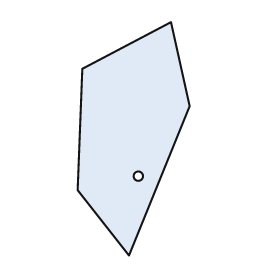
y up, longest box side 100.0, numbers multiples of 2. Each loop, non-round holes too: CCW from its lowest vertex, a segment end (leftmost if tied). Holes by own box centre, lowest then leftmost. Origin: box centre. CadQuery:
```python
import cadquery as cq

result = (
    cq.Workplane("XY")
    .moveTo(-2.0, -50.0)
    .lineTo(24.0, 14.0)
    .lineTo(16.0, 50.0)
    .lineTo(-22.0, 30.0)
    .lineTo(-24.0, -22.0)
    .close()
    .moveTo(2.0, -16.0)
    .circle(2.0)
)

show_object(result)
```